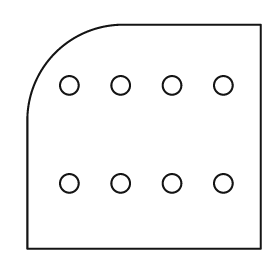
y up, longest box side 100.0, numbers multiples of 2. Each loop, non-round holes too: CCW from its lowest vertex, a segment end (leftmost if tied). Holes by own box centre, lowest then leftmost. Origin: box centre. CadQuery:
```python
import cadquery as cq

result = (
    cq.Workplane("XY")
    .moveTo(-50.0, -48.0)
    .lineTo(50.0, -48.0)
    .lineTo(50.0, 48.0)
    .lineTo(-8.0, 48.0)
    .threePointArc((-38.0, 36.0), (-50.0, 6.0))
    .close()
    .moveTo(-32.0, -20.0)
    .circle(4.0)
    .moveTo(-10.0, -20.0)
    .circle(4.0)
    .moveTo(12.0, -20.0)
    .circle(4.0)
    .moveTo(34.0, -20.0)
    .circle(4.0)
    .moveTo(-32.0, 22.0)
    .circle(4.0)
    .moveTo(-10.0, 22.0)
    .circle(4.0)
    .moveTo(12.0, 22.0)
    .circle(4.0)
    .moveTo(34.0, 22.0)
    .circle(4.0)
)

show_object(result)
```